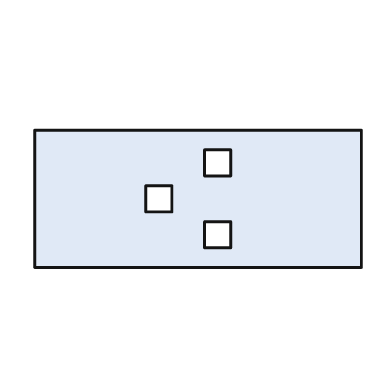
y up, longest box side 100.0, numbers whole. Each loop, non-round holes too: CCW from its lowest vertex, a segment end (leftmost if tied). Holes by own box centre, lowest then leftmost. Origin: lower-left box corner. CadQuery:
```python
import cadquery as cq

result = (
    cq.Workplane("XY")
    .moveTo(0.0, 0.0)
    .lineTo(100.0, 0.0)
    .lineTo(100.0, 42.0)
    .lineTo(0.0, 42.0)
    .close()
    .moveTo(52.0, 6.0)
    .lineTo(60.0, 6.0)
    .lineTo(60.0, 14.0)
    .lineTo(52.0, 14.0)
    .close()
    .moveTo(34.0, 17.0)
    .lineTo(42.0, 17.0)
    .lineTo(42.0, 25.0)
    .lineTo(34.0, 25.0)
    .close()
    .moveTo(52.0, 28.0)
    .lineTo(60.0, 28.0)
    .lineTo(60.0, 36.0)
    .lineTo(52.0, 36.0)
    .close()
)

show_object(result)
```